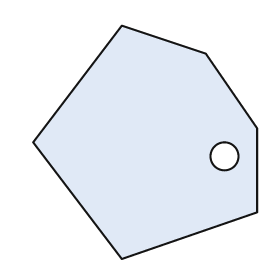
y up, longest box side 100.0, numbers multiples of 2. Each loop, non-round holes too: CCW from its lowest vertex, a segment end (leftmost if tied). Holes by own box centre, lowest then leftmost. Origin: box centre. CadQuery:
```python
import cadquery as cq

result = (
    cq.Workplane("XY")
    .moveTo(-10.0, -50.0)
    .lineTo(48.0, -30.0)
    .lineTo(48.0, 6.0)
    .lineTo(26.0, 38.0)
    .lineTo(-10.0, 50.0)
    .lineTo(-48.0, 0.0)
    .close()
    .moveTo(34.0, -6.0)
    .circle(6.0)
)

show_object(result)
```